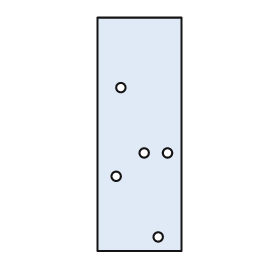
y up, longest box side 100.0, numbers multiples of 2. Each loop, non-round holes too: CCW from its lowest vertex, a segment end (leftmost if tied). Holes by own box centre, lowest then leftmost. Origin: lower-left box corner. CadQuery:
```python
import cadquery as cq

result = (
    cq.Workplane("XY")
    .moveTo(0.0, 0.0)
    .lineTo(36.0, 0.0)
    .lineTo(36.0, 100.0)
    .lineTo(0.0, 100.0)
    .close()
    .moveTo(26.0, 6.0)
    .circle(2.0)
    .moveTo(8.0, 32.0)
    .circle(2.0)
    .moveTo(20.0, 42.0)
    .circle(2.0)
    .moveTo(30.0, 42.0)
    .circle(2.0)
    .moveTo(10.0, 70.0)
    .circle(2.0)
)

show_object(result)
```